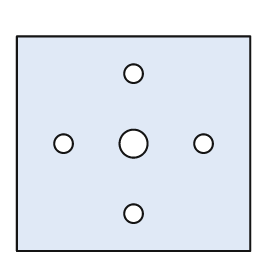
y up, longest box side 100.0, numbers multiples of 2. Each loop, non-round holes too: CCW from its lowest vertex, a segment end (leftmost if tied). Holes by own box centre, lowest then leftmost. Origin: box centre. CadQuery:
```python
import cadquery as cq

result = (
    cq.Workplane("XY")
    .moveTo(-50.0, -46.0)
    .lineTo(50.0, -46.0)
    .lineTo(50.0, 46.0)
    .lineTo(-50.0, 46.0)
    .close()
    .moveTo(0.0, -30.0)
    .circle(4.0)
    .moveTo(-30.0, 0.0)
    .circle(4.0)
    .moveTo(0.0, 0.0)
    .circle(6.0)
    .moveTo(30.0, 0.0)
    .circle(4.0)
    .moveTo(0.0, 30.0)
    .circle(4.0)
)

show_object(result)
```